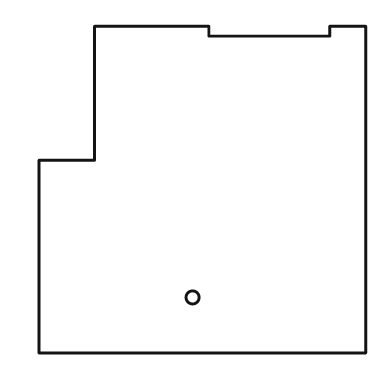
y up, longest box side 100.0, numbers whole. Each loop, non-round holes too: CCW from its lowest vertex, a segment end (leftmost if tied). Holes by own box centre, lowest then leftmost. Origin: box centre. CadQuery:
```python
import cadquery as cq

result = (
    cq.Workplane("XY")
    .moveTo(-50.0, -50.0)
    .lineTo(50.0, -50.0)
    .lineTo(50.0, 50.0)
    .lineTo(39.0, 50.0)
    .lineTo(39.0, 47.0)
    .lineTo(2.0, 47.0)
    .lineTo(2.0, 50.0)
    .lineTo(-33.0, 50.0)
    .lineTo(-33.0, 9.0)
    .lineTo(-50.0, 9.0)
    .close()
    .moveTo(-3.0, -33.0)
    .circle(2.0)
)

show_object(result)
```